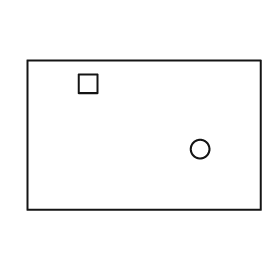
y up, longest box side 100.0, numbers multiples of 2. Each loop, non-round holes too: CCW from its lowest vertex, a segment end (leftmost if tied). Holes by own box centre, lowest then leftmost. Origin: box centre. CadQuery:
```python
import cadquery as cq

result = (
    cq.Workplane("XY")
    .moveTo(-50.0, -32.0)
    .lineTo(50.0, -32.0)
    .lineTo(50.0, 32.0)
    .lineTo(-50.0, 32.0)
    .close()
    .moveTo(24.0, -6.0)
    .circle(4.0)
    .moveTo(-28.0, 18.0)
    .lineTo(-20.0, 18.0)
    .lineTo(-20.0, 26.0)
    .lineTo(-28.0, 26.0)
    .close()
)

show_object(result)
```